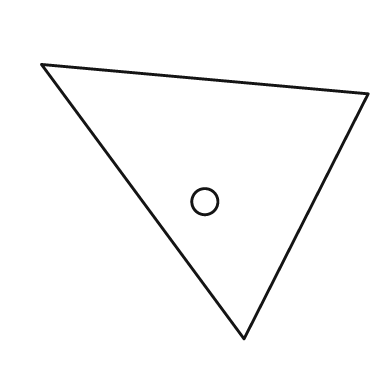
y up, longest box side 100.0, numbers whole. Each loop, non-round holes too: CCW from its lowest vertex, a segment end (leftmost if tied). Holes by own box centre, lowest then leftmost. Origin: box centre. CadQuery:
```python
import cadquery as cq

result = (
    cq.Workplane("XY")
    .moveTo(12.0, -42.0)
    .lineTo(50.0, 33.0)
    .lineTo(-50.0, 42.0)
    .close()
    .moveTo(0.0, 0.0)
    .circle(4.0)
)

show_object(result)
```